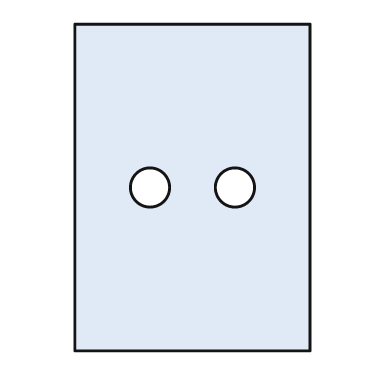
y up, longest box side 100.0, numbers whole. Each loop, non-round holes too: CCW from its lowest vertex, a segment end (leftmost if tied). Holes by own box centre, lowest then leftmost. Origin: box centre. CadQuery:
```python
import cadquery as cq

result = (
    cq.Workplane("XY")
    .moveTo(-36.0, -50.0)
    .lineTo(36.0, -50.0)
    .lineTo(36.0, 50.0)
    .lineTo(-36.0, 50.0)
    .close()
    .moveTo(-13.0, 0.0)
    .circle(6.0)
    .moveTo(13.0, 0.0)
    .circle(6.0)
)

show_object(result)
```